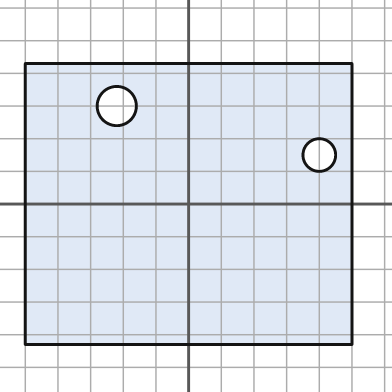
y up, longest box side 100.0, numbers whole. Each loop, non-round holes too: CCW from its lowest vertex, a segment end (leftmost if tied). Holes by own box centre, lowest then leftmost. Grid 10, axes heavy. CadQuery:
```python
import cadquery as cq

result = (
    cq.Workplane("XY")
    .moveTo(-50.0, -43.0)
    .lineTo(50.0, -43.0)
    .lineTo(50.0, 43.0)
    .lineTo(-50.0, 43.0)
    .close()
    .moveTo(40.0, 15.0)
    .circle(5.0)
    .moveTo(-22.0, 30.0)
    .circle(6.0)
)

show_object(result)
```